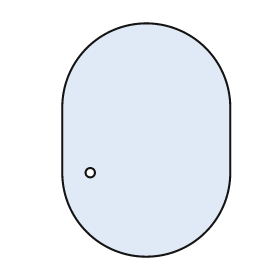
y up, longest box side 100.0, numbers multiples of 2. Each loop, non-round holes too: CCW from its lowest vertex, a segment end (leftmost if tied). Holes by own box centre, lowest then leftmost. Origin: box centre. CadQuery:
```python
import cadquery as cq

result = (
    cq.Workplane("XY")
    .moveTo(-36.0, -14.0)
    .threePointArc((0.0, -50.0), (36.0, -14.0))
    .lineTo(36.0, 14.0)
    .threePointArc((0.0, 50.0), (-36.0, 14.0))
    .close()
    .moveTo(-24.0, -14.0)
    .circle(2.0)
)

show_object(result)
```